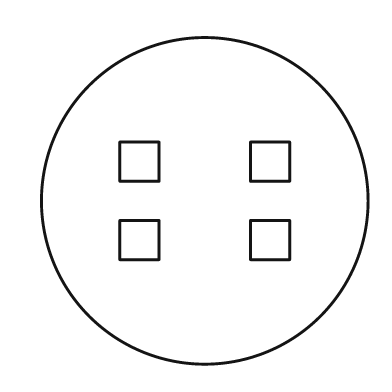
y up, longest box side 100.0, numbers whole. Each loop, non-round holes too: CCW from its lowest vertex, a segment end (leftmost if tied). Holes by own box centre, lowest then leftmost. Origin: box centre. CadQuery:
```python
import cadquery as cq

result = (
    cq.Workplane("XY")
    .moveTo(0.0, 0.0)
    .circle(50.0)
    .moveTo(-26.0, -18.0)
    .lineTo(-14.0, -18.0)
    .lineTo(-14.0, -6.0)
    .lineTo(-26.0, -6.0)
    .close()
    .moveTo(14.0, -18.0)
    .lineTo(26.0, -18.0)
    .lineTo(26.0, -6.0)
    .lineTo(14.0, -6.0)
    .close()
    .moveTo(-26.0, 6.0)
    .lineTo(-14.0, 6.0)
    .lineTo(-14.0, 18.0)
    .lineTo(-26.0, 18.0)
    .close()
    .moveTo(14.0, 6.0)
    .lineTo(26.0, 6.0)
    .lineTo(26.0, 18.0)
    .lineTo(14.0, 18.0)
    .close()
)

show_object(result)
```